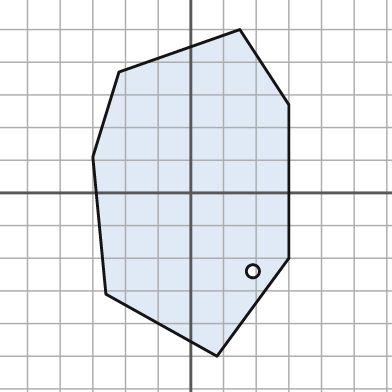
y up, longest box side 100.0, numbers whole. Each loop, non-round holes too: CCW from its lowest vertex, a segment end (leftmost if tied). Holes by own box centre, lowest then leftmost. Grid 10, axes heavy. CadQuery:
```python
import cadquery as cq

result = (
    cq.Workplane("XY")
    .moveTo(8.0, -50.0)
    .lineTo(30.0, -20.0)
    .lineTo(30.0, 27.0)
    .lineTo(15.0, 50.0)
    .lineTo(-22.0, 37.0)
    .lineTo(-30.0, 11.0)
    .lineTo(-26.0, -31.0)
    .close()
    .moveTo(19.0, -24.0)
    .circle(2.0)
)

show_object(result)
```